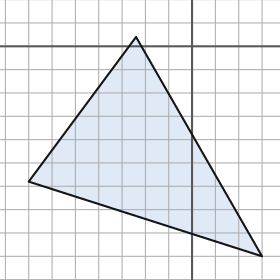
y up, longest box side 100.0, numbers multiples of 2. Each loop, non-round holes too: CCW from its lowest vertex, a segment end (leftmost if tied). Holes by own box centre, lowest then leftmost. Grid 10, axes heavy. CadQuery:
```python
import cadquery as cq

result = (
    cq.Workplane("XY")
    .moveTo(30.0, -90.0)
    .lineTo(-24.0, 4.0)
    .lineTo(-70.0, -58.0)
    .close()
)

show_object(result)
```